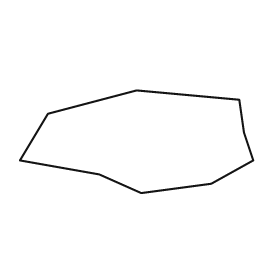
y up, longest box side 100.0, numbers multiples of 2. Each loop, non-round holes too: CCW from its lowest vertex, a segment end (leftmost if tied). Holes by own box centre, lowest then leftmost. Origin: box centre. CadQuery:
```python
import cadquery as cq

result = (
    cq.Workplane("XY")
    .moveTo(2.0, -22.0)
    .lineTo(32.0, -18.0)
    .lineTo(50.0, -8.0)
    .lineTo(46.0, 4.0)
    .lineTo(44.0, 18.0)
    .lineTo(0.0, 22.0)
    .lineTo(-38.0, 12.0)
    .lineTo(-50.0, -8.0)
    .lineTo(-16.0, -14.0)
    .close()
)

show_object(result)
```